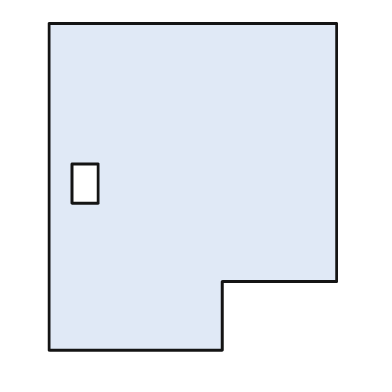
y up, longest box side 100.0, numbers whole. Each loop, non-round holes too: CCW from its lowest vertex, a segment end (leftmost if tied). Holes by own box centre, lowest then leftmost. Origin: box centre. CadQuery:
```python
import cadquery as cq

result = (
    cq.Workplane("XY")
    .moveTo(-44.0, -50.0)
    .lineTo(9.0, -50.0)
    .lineTo(9.0, -29.0)
    .lineTo(44.0, -29.0)
    .lineTo(44.0, 50.0)
    .lineTo(-44.0, 50.0)
    .close()
    .moveTo(-37.0, -5.0)
    .lineTo(-29.0, -5.0)
    .lineTo(-29.0, 7.0)
    .lineTo(-37.0, 7.0)
    .close()
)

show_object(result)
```